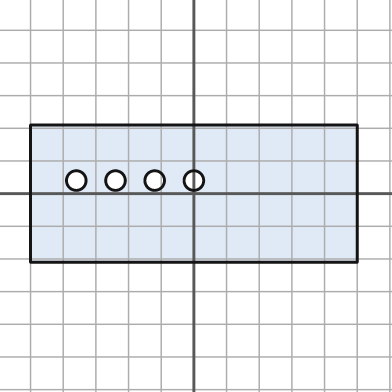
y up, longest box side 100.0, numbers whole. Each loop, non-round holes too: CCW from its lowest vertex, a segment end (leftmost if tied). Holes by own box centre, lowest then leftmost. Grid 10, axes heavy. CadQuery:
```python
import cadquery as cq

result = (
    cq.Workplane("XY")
    .moveTo(-50.0, -21.0)
    .lineTo(50.0, -21.0)
    .lineTo(50.0, 21.0)
    .lineTo(-50.0, 21.0)
    .close()
    .moveTo(-36.0, 4.0)
    .circle(3.0)
    .moveTo(-24.0, 4.0)
    .circle(3.0)
    .moveTo(-12.0, 4.0)
    .circle(3.0)
    .moveTo(0.0, 4.0)
    .circle(3.0)
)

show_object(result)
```